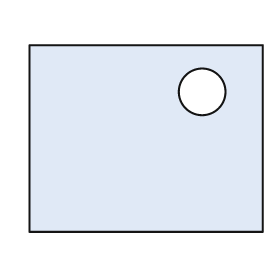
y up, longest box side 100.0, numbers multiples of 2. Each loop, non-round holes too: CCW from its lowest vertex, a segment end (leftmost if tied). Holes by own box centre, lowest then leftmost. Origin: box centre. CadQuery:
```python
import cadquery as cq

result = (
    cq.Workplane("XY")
    .moveTo(-50.0, -40.0)
    .lineTo(50.0, -40.0)
    .lineTo(50.0, 40.0)
    .lineTo(-50.0, 40.0)
    .close()
    .moveTo(24.0, 20.0)
    .circle(10.0)
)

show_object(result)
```